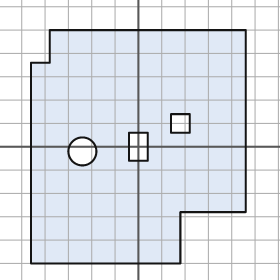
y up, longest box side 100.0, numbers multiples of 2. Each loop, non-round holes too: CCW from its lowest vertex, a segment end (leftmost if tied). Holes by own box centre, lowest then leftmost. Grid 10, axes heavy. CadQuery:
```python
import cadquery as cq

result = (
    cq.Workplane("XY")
    .moveTo(-46.0, -50.0)
    .lineTo(18.0, -50.0)
    .lineTo(18.0, -28.0)
    .lineTo(46.0, -28.0)
    .lineTo(46.0, 50.0)
    .lineTo(-38.0, 50.0)
    .lineTo(-38.0, 36.0)
    .lineTo(-46.0, 36.0)
    .close()
    .moveTo(-24.0, -2.0)
    .circle(6.0)
    .moveTo(-4.0, -6.0)
    .lineTo(4.0, -6.0)
    .lineTo(4.0, 6.0)
    .lineTo(-4.0, 6.0)
    .close()
    .moveTo(14.0, 6.0)
    .lineTo(22.0, 6.0)
    .lineTo(22.0, 14.0)
    .lineTo(14.0, 14.0)
    .close()
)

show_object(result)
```